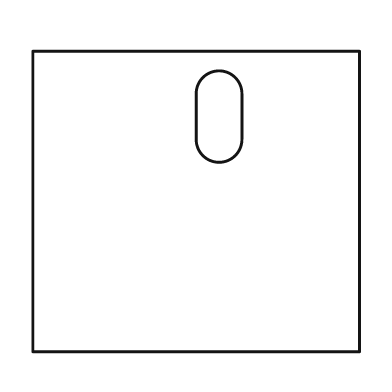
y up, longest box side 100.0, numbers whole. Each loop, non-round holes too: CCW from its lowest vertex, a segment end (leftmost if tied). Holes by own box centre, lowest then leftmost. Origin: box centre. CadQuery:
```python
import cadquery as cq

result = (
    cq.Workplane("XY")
    .moveTo(-50.0, -46.0)
    .lineTo(50.0, -46.0)
    .lineTo(50.0, 46.0)
    .lineTo(-50.0, 46.0)
    .close()
    .moveTo(0.0, 19.0)
    .threePointArc((7.0, 12.0), (14.0, 19.0))
    .lineTo(14.0, 33.0)
    .threePointArc((7.0, 40.0), (0.0, 33.0))
    .close()
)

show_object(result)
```